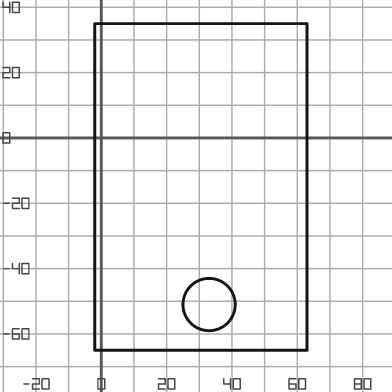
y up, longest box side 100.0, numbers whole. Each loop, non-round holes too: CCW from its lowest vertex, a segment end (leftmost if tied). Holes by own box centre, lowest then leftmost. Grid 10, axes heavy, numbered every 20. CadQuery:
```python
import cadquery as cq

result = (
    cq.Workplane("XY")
    .moveTo(-2.0, -65.0)
    .lineTo(63.0, -65.0)
    .lineTo(63.0, 35.0)
    .lineTo(-2.0, 35.0)
    .close()
    .moveTo(33.0, -51.0)
    .circle(8.0)
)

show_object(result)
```